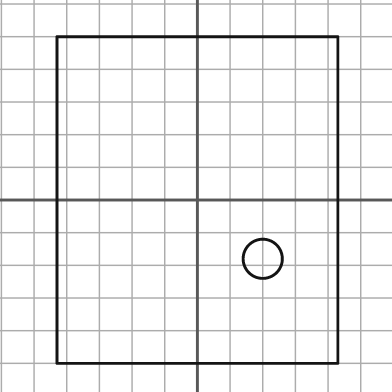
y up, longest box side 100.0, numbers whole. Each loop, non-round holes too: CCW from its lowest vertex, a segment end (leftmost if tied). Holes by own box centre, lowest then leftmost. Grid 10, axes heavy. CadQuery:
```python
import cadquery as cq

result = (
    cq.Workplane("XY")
    .moveTo(-43.0, -50.0)
    .lineTo(43.0, -50.0)
    .lineTo(43.0, 50.0)
    .lineTo(-43.0, 50.0)
    .close()
    .moveTo(20.0, -18.0)
    .circle(6.0)
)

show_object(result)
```